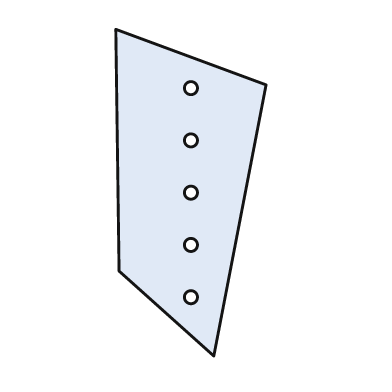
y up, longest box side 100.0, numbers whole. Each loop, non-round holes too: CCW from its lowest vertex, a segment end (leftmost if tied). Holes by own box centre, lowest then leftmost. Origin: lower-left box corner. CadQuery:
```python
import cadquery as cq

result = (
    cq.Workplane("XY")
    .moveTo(30.0, 0.0)
    .lineTo(46.0, 83.0)
    .lineTo(0.0, 100.0)
    .lineTo(1.0, 26.0)
    .close()
    .moveTo(23.0, 18.0)
    .circle(2.0)
    .moveTo(23.0, 34.0)
    .circle(2.0)
    .moveTo(23.0, 50.0)
    .circle(2.0)
    .moveTo(23.0, 66.0)
    .circle(2.0)
    .moveTo(23.0, 82.0)
    .circle(2.0)
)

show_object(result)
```